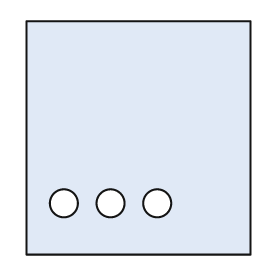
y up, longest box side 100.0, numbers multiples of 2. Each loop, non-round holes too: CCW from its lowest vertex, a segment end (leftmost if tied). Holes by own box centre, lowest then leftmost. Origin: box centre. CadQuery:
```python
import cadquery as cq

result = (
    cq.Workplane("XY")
    .moveTo(-48.0, -50.0)
    .lineTo(48.0, -50.0)
    .lineTo(48.0, 50.0)
    .lineTo(-48.0, 50.0)
    .close()
    .moveTo(-32.0, -28.0)
    .circle(6.0)
    .moveTo(-12.0, -28.0)
    .circle(6.0)
    .moveTo(8.0, -28.0)
    .circle(6.0)
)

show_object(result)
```